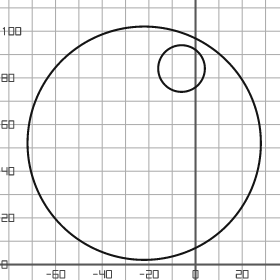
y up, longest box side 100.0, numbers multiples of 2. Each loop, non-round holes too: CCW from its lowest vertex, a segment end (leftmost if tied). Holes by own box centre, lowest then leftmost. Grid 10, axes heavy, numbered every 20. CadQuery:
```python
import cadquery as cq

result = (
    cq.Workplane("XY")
    .moveTo(-22.0, 52.0)
    .circle(50.0)
    .moveTo(-6.0, 84.0)
    .circle(10.0)
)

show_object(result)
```